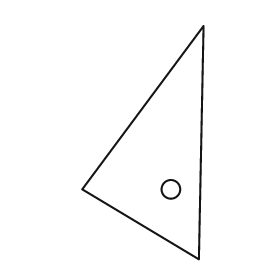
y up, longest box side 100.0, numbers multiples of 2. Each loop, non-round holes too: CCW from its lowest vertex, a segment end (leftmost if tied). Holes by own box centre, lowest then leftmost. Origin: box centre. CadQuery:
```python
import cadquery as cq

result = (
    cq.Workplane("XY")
    .moveTo(24.0, -50.0)
    .lineTo(26.0, 50.0)
    .lineTo(-26.0, -20.0)
    .close()
    .moveTo(12.0, -20.0)
    .circle(4.0)
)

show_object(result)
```